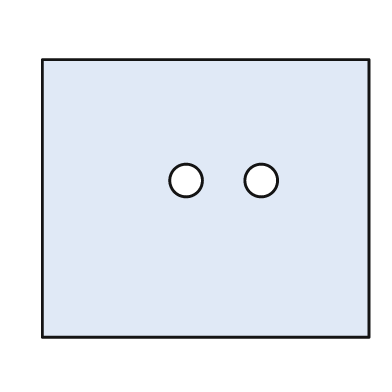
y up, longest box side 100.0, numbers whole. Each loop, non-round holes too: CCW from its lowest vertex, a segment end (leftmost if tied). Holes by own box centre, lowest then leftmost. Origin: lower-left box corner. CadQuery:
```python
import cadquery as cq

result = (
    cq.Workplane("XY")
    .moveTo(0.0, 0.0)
    .lineTo(100.0, 0.0)
    .lineTo(100.0, 85.0)
    .lineTo(0.0, 85.0)
    .close()
    .moveTo(44.0, 48.0)
    .circle(5.0)
    .moveTo(67.0, 48.0)
    .circle(5.0)
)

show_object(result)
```